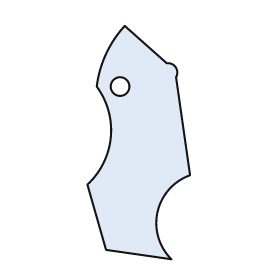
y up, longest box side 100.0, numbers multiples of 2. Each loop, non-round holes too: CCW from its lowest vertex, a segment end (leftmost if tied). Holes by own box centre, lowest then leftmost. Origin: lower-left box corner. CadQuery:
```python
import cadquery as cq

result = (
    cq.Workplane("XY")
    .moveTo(36.0, 0.0)
    .threePointArc((30.0, 20.0), (44.0, 36.0))
    .lineTo(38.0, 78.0)
    .threePointArc((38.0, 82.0), (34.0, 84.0))
    .lineTo(16.0, 100.0)
    .threePointArc((8.0, 88.0), (4.0, 74.0))
    .threePointArc((10.0, 52.0), (0.0, 32.0))
    .lineTo(8.0, 4.0)
    .close()
    .moveTo(14.0, 74.0)
    .circle(4.0)
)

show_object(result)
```